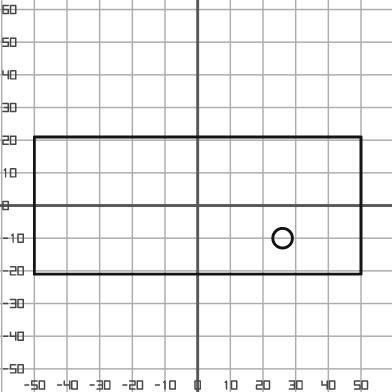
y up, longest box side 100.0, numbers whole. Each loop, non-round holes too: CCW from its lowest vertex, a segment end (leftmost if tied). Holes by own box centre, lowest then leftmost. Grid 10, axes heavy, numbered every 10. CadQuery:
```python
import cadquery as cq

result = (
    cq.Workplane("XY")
    .moveTo(-50.0, -21.0)
    .lineTo(50.0, -21.0)
    .lineTo(50.0, 21.0)
    .lineTo(-50.0, 21.0)
    .close()
    .moveTo(26.0, -10.0)
    .circle(3.0)
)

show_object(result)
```